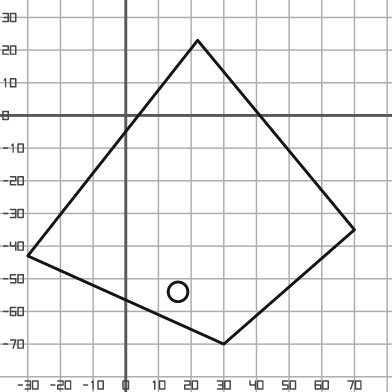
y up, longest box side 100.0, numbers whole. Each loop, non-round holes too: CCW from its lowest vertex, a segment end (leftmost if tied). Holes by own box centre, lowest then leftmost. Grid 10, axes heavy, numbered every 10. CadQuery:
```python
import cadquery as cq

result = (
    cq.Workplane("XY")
    .moveTo(30.0, -70.0)
    .lineTo(70.0, -35.0)
    .lineTo(22.0, 23.0)
    .lineTo(-30.0, -43.0)
    .close()
    .moveTo(16.0, -54.0)
    .circle(3.0)
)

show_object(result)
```